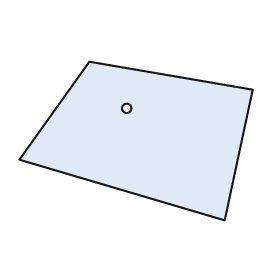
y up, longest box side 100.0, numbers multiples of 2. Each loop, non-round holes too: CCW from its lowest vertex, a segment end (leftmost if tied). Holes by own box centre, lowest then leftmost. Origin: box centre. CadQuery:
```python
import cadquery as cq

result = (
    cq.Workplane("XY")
    .moveTo(38.0, -34.0)
    .lineTo(50.0, 22.0)
    .lineTo(-20.0, 34.0)
    .lineTo(-50.0, -8.0)
    .close()
    .moveTo(-4.0, 14.0)
    .circle(2.0)
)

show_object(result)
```